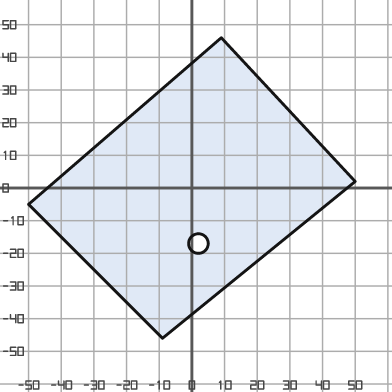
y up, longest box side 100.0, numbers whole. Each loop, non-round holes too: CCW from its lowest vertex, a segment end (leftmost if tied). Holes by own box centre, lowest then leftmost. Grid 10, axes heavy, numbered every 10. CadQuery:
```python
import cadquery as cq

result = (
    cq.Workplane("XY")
    .moveTo(-9.0, -46.0)
    .lineTo(50.0, 2.0)
    .lineTo(9.0, 46.0)
    .lineTo(-50.0, -5.0)
    .close()
    .moveTo(2.0, -17.0)
    .circle(3.0)
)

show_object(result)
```